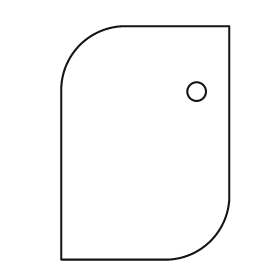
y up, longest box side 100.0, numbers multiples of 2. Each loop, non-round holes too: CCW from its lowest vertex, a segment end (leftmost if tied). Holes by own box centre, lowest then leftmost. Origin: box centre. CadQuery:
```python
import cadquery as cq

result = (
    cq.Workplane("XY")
    .moveTo(-36.0, -50.0)
    .lineTo(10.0, -50.0)
    .threePointArc((28.0, -42.0), (36.0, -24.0))
    .lineTo(36.0, 50.0)
    .lineTo(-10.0, 50.0)
    .threePointArc((-28.0, 42.0), (-36.0, 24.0))
    .close()
    .moveTo(22.0, 22.0)
    .circle(4.0)
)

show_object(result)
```